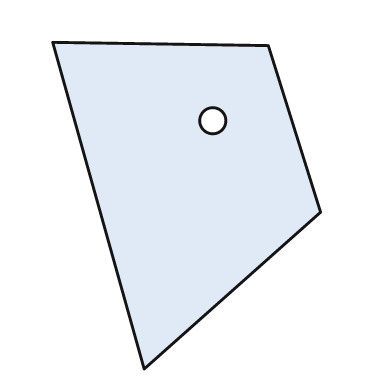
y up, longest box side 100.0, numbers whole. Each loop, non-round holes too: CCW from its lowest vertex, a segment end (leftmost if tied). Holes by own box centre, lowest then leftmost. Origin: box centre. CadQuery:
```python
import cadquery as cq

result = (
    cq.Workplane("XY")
    .moveTo(-13.0, -50.0)
    .lineTo(41.0, -2.0)
    .lineTo(25.0, 49.0)
    .lineTo(-41.0, 50.0)
    .close()
    .moveTo(8.0, 26.0)
    .circle(4.0)
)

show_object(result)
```